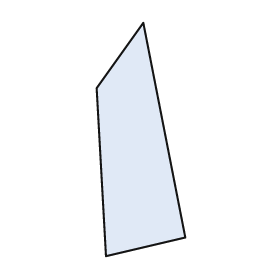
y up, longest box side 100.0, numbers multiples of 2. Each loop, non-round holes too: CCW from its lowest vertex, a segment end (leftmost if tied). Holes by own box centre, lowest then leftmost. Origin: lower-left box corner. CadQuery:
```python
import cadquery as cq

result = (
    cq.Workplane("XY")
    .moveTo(4.0, 0.0)
    .lineTo(38.0, 8.0)
    .lineTo(20.0, 100.0)
    .lineTo(0.0, 72.0)
    .close()
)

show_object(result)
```